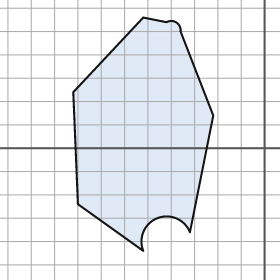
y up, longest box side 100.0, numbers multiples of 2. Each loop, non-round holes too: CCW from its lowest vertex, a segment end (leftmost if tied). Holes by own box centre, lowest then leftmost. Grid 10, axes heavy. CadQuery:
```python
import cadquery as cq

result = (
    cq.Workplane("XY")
    .moveTo(-52.0, -44.0)
    .threePointArc((-46.0, -30.0), (-32.0, -36.0))
    .lineTo(-22.0, 14.0)
    .lineTo(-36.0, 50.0)
    .threePointArc((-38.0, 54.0), (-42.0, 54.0))
    .lineTo(-52.0, 56.0)
    .lineTo(-82.0, 24.0)
    .lineTo(-80.0, -24.0)
    .close()
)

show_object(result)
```